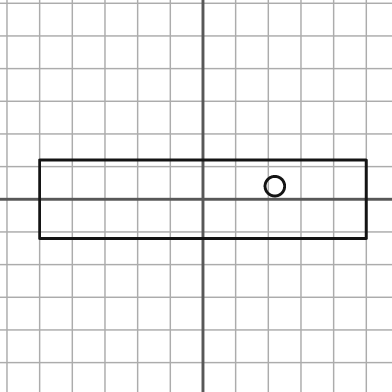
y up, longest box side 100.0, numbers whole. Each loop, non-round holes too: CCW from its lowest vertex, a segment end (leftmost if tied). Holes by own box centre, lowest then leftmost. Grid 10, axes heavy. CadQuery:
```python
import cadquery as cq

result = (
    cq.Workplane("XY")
    .moveTo(-50.0, -12.0)
    .lineTo(50.0, -12.0)
    .lineTo(50.0, 12.0)
    .lineTo(-50.0, 12.0)
    .close()
    .moveTo(22.0, 4.0)
    .circle(3.0)
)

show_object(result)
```